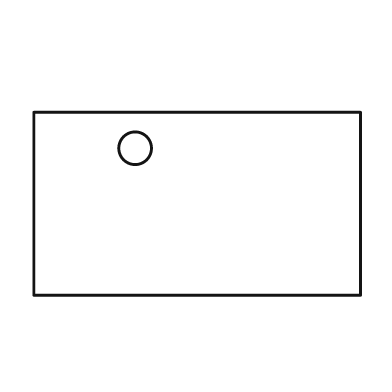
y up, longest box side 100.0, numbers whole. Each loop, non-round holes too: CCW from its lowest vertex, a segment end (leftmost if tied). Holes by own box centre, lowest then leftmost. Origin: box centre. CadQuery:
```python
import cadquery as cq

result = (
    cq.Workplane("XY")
    .moveTo(-50.0, -28.0)
    .lineTo(50.0, -28.0)
    .lineTo(50.0, 28.0)
    .lineTo(-50.0, 28.0)
    .close()
    .moveTo(-19.0, 17.0)
    .circle(5.0)
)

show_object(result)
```